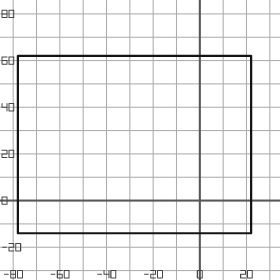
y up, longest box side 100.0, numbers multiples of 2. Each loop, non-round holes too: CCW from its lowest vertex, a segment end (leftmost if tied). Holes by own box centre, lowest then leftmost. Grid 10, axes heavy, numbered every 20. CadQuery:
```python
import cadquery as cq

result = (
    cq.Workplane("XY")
    .moveTo(-78.0, -14.0)
    .lineTo(22.0, -14.0)
    .lineTo(22.0, 62.0)
    .lineTo(-78.0, 62.0)
    .close()
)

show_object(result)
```